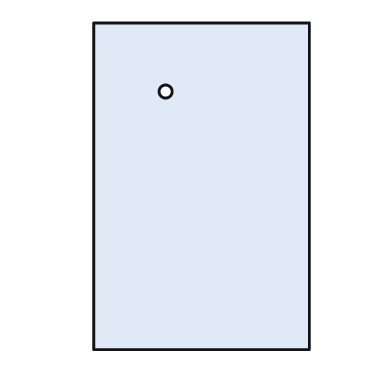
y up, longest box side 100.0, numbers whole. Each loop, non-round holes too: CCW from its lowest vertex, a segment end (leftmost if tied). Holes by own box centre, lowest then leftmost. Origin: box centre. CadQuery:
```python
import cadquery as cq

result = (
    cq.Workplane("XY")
    .moveTo(-33.0, -50.0)
    .lineTo(33.0, -50.0)
    .lineTo(33.0, 50.0)
    .lineTo(-33.0, 50.0)
    .close()
    .moveTo(-11.0, 29.0)
    .circle(2.0)
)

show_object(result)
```